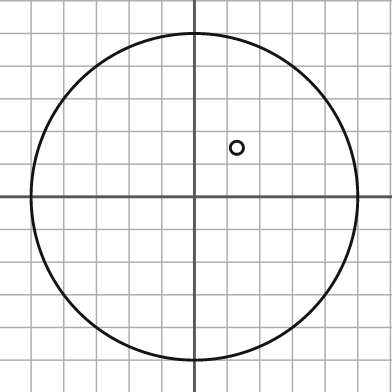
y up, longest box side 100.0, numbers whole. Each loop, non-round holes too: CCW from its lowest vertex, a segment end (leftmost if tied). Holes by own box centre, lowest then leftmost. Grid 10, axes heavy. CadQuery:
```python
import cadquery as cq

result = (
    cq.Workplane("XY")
    .moveTo(0.0, 0.0)
    .circle(50.0)
    .moveTo(13.0, 15.0)
    .circle(2.0)
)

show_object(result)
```